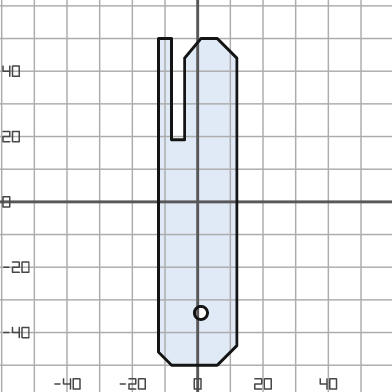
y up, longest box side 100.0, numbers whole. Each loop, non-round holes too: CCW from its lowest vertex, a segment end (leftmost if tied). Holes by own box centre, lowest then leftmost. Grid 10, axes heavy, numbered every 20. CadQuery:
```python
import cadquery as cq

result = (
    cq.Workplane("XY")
    .moveTo(-8.0, -50.0)
    .lineTo(6.0, -50.0)
    .lineTo(12.0, -44.0)
    .lineTo(12.0, 44.0)
    .lineTo(6.0, 50.0)
    .lineTo(1.0, 50.0)
    .lineTo(-4.0, 44.0)
    .lineTo(-4.0, 19.0)
    .lineTo(-8.0, 19.0)
    .lineTo(-8.0, 50.0)
    .lineTo(-12.0, 50.0)
    .lineTo(-12.0, -46.0)
    .close()
    .moveTo(1.0, -34.0)
    .circle(2.0)
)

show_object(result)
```